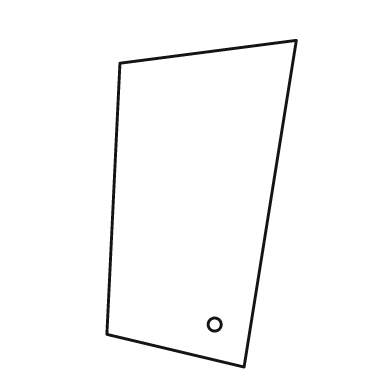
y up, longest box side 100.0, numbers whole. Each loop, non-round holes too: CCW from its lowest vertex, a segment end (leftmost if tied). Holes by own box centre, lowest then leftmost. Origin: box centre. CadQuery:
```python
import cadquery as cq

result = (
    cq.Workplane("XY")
    .moveTo(13.0, -50.0)
    .lineTo(29.0, 50.0)
    .lineTo(-25.0, 43.0)
    .lineTo(-29.0, -40.0)
    .close()
    .moveTo(4.0, -37.0)
    .circle(2.0)
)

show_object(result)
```